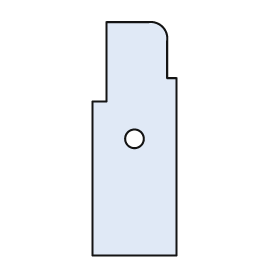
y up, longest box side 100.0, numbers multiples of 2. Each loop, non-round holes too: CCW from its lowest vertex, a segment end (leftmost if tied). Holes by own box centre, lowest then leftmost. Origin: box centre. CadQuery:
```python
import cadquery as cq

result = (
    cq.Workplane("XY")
    .moveTo(-18.0, -50.0)
    .lineTo(18.0, -50.0)
    .lineTo(18.0, 26.0)
    .lineTo(14.0, 26.0)
    .lineTo(14.0, 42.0)
    .threePointArc((12.0, 48.0), (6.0, 50.0))
    .lineTo(-12.0, 50.0)
    .lineTo(-12.0, 16.0)
    .lineTo(-18.0, 16.0)
    .close()
    .moveTo(0.0, 0.0)
    .circle(4.0)
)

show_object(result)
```